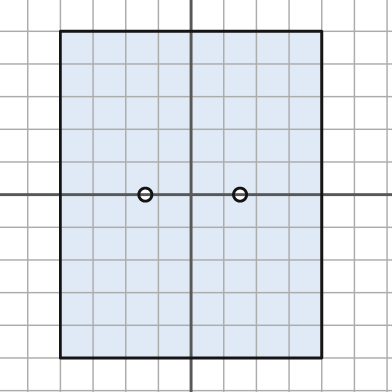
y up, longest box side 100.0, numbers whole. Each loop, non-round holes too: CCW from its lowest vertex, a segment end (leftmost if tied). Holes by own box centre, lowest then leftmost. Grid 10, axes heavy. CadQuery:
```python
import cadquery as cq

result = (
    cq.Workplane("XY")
    .moveTo(-40.0, -50.0)
    .lineTo(40.0, -50.0)
    .lineTo(40.0, 50.0)
    .lineTo(-40.0, 50.0)
    .close()
    .moveTo(-14.0, 0.0)
    .circle(2.0)
    .moveTo(15.0, 0.0)
    .circle(2.0)
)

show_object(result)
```